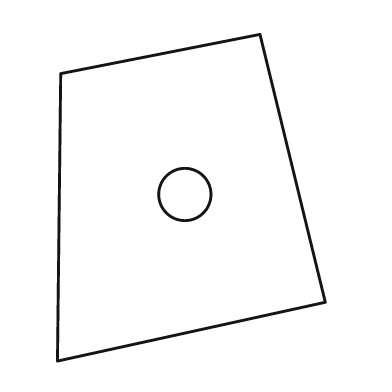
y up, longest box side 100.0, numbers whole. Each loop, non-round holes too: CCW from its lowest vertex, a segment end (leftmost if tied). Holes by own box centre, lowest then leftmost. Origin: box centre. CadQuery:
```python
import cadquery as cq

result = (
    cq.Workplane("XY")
    .moveTo(-41.0, -50.0)
    .lineTo(41.0, -32.0)
    .lineTo(21.0, 50.0)
    .lineTo(-40.0, 38.0)
    .close()
    .moveTo(-2.0, 1.0)
    .circle(8.0)
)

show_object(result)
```